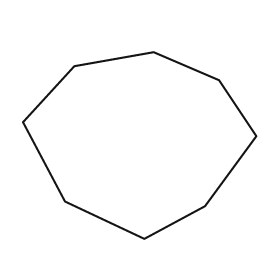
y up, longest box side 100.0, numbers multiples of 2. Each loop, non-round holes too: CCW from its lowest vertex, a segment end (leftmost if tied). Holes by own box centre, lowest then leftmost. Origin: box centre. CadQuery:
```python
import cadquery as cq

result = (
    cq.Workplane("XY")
    .moveTo(2.0, -40.0)
    .lineTo(28.0, -26.0)
    .lineTo(50.0, 4.0)
    .lineTo(34.0, 28.0)
    .lineTo(6.0, 40.0)
    .lineTo(-28.0, 34.0)
    .lineTo(-50.0, 10.0)
    .lineTo(-32.0, -24.0)
    .close()
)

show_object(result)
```